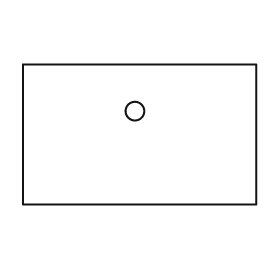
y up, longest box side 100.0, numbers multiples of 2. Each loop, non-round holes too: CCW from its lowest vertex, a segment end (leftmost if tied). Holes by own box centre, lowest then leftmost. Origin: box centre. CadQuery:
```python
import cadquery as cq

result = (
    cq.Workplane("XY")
    .moveTo(-50.0, -30.0)
    .lineTo(50.0, -30.0)
    .lineTo(50.0, 30.0)
    .lineTo(-50.0, 30.0)
    .close()
    .moveTo(-2.0, 10.0)
    .circle(4.0)
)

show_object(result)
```